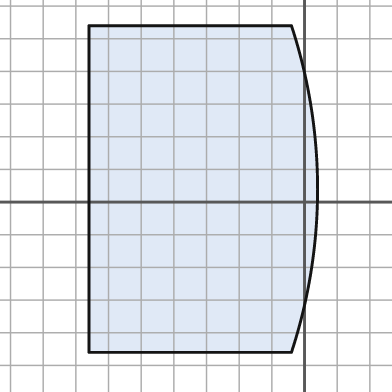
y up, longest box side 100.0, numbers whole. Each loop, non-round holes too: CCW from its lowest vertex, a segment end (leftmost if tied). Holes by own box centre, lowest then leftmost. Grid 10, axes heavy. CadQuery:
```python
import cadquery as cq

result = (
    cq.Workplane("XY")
    .moveTo(-66.0, -46.0)
    .lineTo(-4.0, -46.0)
    .threePointArc((4.0, 4.0), (-4.0, 54.0))
    .lineTo(-66.0, 54.0)
    .close()
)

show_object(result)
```